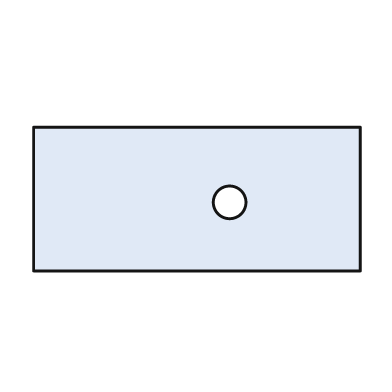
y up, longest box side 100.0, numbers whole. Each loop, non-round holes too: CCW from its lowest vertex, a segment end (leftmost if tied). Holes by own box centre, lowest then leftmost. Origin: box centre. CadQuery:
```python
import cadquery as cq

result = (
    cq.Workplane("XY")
    .moveTo(-50.0, -22.0)
    .lineTo(50.0, -22.0)
    .lineTo(50.0, 22.0)
    .lineTo(-50.0, 22.0)
    .close()
    .moveTo(10.0, -1.0)
    .circle(5.0)
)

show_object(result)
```